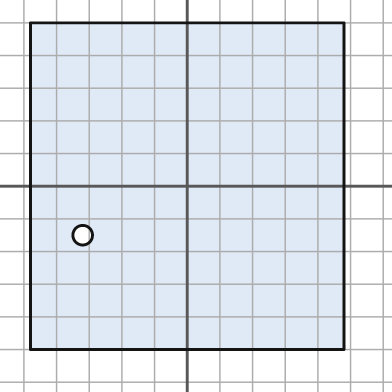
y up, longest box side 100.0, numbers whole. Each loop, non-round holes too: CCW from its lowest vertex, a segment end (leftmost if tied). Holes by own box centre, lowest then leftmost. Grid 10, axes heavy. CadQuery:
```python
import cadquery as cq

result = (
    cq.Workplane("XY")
    .moveTo(-48.0, -50.0)
    .lineTo(48.0, -50.0)
    .lineTo(48.0, 50.0)
    .lineTo(-48.0, 50.0)
    .close()
    .moveTo(-32.0, -15.0)
    .circle(3.0)
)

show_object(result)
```